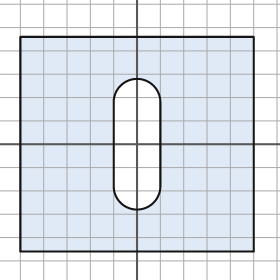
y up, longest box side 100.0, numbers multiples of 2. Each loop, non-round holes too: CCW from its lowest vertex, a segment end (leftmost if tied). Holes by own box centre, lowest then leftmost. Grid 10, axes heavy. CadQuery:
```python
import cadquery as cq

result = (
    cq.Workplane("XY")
    .moveTo(-50.0, -46.0)
    .lineTo(50.0, -46.0)
    .lineTo(50.0, 46.0)
    .lineTo(-50.0, 46.0)
    .close()
    .moveTo(-10.0, -18.0)
    .threePointArc((0.0, -28.0), (10.0, -18.0))
    .lineTo(10.0, 18.0)
    .threePointArc((0.0, 28.0), (-10.0, 18.0))
    .close()
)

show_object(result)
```